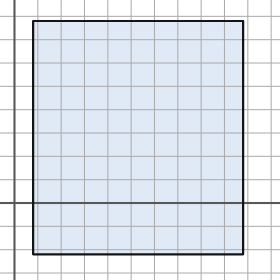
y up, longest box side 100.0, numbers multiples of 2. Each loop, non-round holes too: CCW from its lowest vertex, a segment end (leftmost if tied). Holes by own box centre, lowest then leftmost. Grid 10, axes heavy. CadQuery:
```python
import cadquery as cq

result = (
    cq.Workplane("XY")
    .moveTo(8.0, -22.0)
    .lineTo(98.0, -22.0)
    .lineTo(98.0, 78.0)
    .lineTo(8.0, 78.0)
    .close()
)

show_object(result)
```